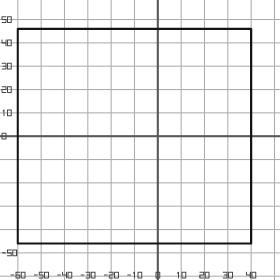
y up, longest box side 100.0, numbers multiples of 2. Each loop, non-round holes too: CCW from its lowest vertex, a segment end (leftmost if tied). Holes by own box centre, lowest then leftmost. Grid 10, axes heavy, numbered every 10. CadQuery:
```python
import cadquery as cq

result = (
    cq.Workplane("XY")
    .moveTo(-60.0, -46.0)
    .lineTo(40.0, -46.0)
    .lineTo(40.0, 46.0)
    .lineTo(-60.0, 46.0)
    .close()
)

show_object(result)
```